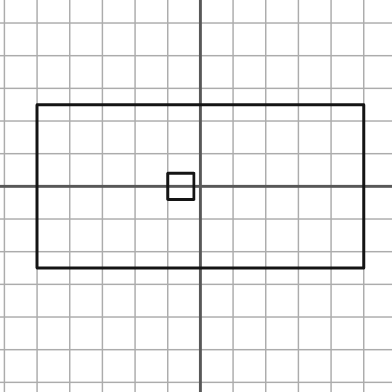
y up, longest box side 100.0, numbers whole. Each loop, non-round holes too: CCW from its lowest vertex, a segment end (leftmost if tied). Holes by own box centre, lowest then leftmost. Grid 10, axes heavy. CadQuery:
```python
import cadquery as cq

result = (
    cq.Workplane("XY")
    .moveTo(-50.0, -25.0)
    .lineTo(50.0, -25.0)
    .lineTo(50.0, 25.0)
    .lineTo(-50.0, 25.0)
    .close()
    .moveTo(-10.0, -4.0)
    .lineTo(-2.0, -4.0)
    .lineTo(-2.0, 4.0)
    .lineTo(-10.0, 4.0)
    .close()
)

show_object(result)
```